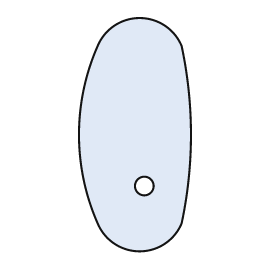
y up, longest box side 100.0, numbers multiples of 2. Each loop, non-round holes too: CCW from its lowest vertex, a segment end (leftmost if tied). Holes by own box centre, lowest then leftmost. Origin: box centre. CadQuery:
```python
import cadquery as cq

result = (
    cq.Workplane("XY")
    .moveTo(-16.0, -38.0)
    .threePointArc((2.0, -50.0), (20.0, -38.0))
    .threePointArc((24.0, 0.0), (20.0, 38.0))
    .threePointArc((2.0, 50.0), (-16.0, 38.0))
    .threePointArc((-24.0, 0.0), (-16.0, -38.0))
    .close()
    .moveTo(4.0, -22.0)
    .circle(4.0)
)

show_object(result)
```